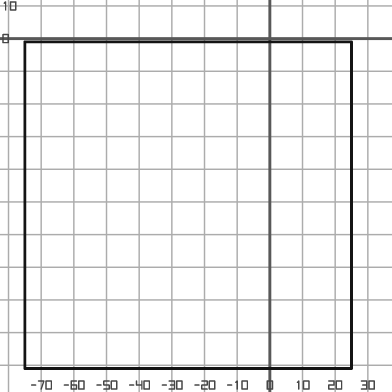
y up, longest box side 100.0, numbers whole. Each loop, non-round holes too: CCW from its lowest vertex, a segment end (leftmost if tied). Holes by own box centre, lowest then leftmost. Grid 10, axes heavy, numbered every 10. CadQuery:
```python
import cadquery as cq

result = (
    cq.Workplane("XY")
    .moveTo(-75.0, -101.0)
    .lineTo(25.0, -101.0)
    .lineTo(25.0, -1.0)
    .lineTo(-75.0, -1.0)
    .close()
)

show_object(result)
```